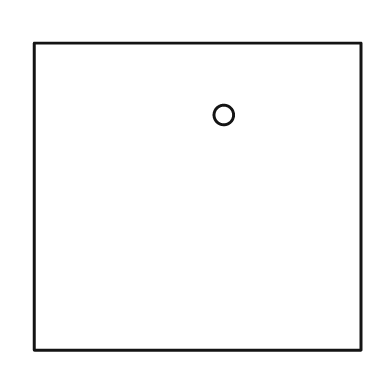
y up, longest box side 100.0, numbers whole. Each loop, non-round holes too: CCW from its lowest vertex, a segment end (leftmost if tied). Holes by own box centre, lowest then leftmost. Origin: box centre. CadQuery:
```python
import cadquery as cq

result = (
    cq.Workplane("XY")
    .moveTo(-50.0, -47.0)
    .lineTo(50.0, -47.0)
    .lineTo(50.0, 47.0)
    .lineTo(-50.0, 47.0)
    .close()
    .moveTo(8.0, 25.0)
    .circle(3.0)
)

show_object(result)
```